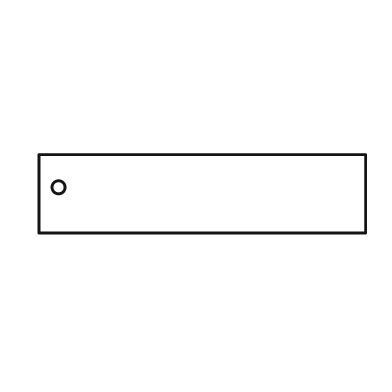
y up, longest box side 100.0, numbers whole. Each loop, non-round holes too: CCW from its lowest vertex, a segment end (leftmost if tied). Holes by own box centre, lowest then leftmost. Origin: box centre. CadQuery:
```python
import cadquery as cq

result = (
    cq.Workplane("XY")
    .moveTo(-50.0, -12.0)
    .lineTo(50.0, -12.0)
    .lineTo(50.0, 12.0)
    .lineTo(-50.0, 12.0)
    .close()
    .moveTo(-44.0, 2.0)
    .circle(2.0)
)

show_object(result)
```